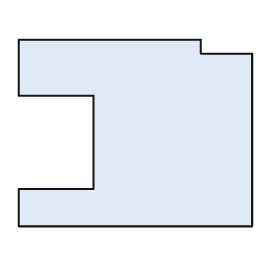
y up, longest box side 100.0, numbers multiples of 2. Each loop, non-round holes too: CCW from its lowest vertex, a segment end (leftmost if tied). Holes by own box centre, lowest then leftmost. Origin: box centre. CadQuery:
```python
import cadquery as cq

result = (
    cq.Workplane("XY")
    .moveTo(-50.0, -40.0)
    .lineTo(50.0, -40.0)
    .lineTo(50.0, 34.0)
    .lineTo(28.0, 34.0)
    .lineTo(28.0, 40.0)
    .lineTo(-50.0, 40.0)
    .lineTo(-50.0, 16.0)
    .lineTo(-18.0, 16.0)
    .lineTo(-18.0, -24.0)
    .lineTo(-50.0, -24.0)
    .close()
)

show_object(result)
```